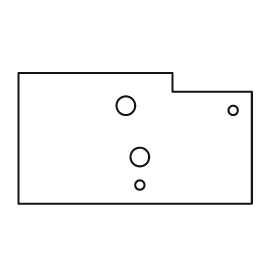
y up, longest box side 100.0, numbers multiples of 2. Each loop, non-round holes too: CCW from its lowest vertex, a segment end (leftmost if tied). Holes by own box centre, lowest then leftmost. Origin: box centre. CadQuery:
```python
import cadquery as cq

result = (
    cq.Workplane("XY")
    .moveTo(-50.0, -28.0)
    .lineTo(50.0, -28.0)
    .lineTo(50.0, 20.0)
    .lineTo(16.0, 20.0)
    .lineTo(16.0, 28.0)
    .lineTo(-50.0, 28.0)
    .close()
    .moveTo(2.0, -20.0)
    .circle(2.0)
    .moveTo(2.0, -8.0)
    .circle(4.0)
    .moveTo(42.0, 12.0)
    .circle(2.0)
    .moveTo(-4.0, 14.0)
    .circle(4.0)
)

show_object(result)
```